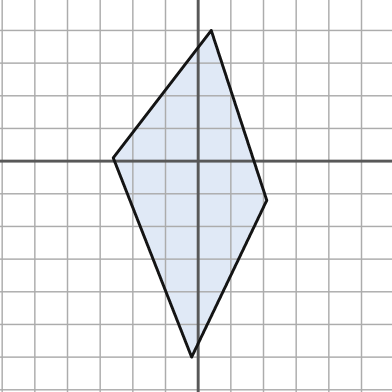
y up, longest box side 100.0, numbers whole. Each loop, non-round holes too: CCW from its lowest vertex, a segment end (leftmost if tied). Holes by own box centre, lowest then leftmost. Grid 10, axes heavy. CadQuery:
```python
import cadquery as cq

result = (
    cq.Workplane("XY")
    .moveTo(-2.0, -60.0)
    .lineTo(21.0, -12.0)
    .lineTo(4.0, 40.0)
    .lineTo(-26.0, 1.0)
    .close()
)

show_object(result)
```